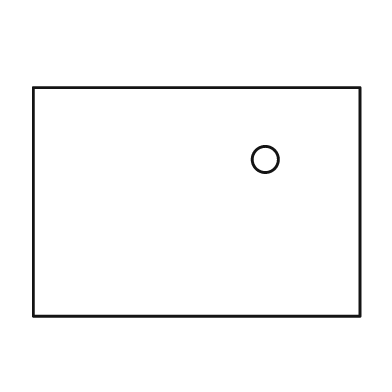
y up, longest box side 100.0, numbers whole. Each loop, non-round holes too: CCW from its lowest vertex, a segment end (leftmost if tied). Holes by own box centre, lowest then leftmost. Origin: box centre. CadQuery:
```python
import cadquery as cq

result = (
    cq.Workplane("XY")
    .moveTo(-50.0, -35.0)
    .lineTo(50.0, -35.0)
    .lineTo(50.0, 35.0)
    .lineTo(-50.0, 35.0)
    .close()
    .moveTo(21.0, 13.0)
    .circle(4.0)
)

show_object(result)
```